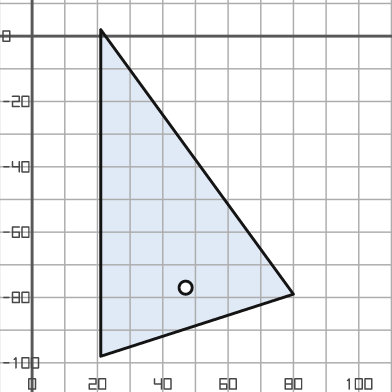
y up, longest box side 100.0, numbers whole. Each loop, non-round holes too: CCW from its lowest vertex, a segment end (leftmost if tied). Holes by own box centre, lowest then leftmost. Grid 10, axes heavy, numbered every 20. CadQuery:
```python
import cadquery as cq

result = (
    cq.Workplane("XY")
    .moveTo(21.0, -98.0)
    .lineTo(80.0, -79.0)
    .lineTo(21.0, 2.0)
    .close()
    .moveTo(47.0, -77.0)
    .circle(2.0)
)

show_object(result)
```